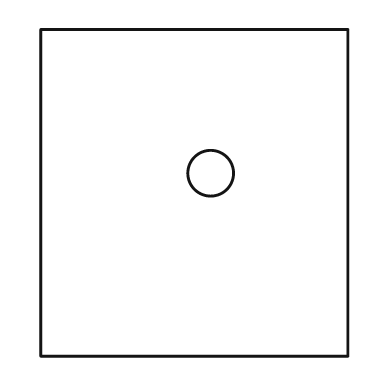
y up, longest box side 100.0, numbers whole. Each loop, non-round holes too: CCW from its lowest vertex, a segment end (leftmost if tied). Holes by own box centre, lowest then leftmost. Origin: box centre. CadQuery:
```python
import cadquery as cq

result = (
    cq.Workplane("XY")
    .moveTo(-47.0, -50.0)
    .lineTo(47.0, -50.0)
    .lineTo(47.0, 50.0)
    .lineTo(-47.0, 50.0)
    .close()
    .moveTo(5.0, 6.0)
    .circle(7.0)
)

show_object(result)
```